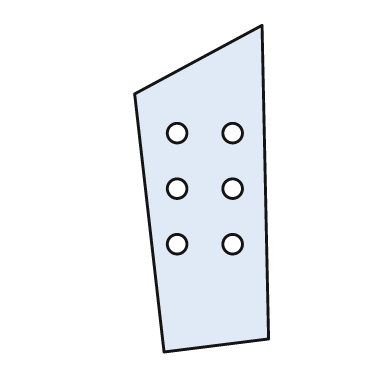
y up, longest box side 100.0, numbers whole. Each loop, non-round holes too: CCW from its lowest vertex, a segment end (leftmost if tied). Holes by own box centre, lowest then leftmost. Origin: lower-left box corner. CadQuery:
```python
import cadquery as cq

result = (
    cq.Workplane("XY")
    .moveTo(9.0, 0.0)
    .lineTo(41.0, 4.0)
    .lineTo(39.0, 100.0)
    .lineTo(0.0, 79.0)
    .close()
    .moveTo(13.0, 33.0)
    .circle(3.0)
    .moveTo(30.0, 33.0)
    .circle(3.0)
    .moveTo(13.0, 50.0)
    .circle(3.0)
    .moveTo(30.0, 50.0)
    .circle(3.0)
    .moveTo(13.0, 67.0)
    .circle(3.0)
    .moveTo(30.0, 67.0)
    .circle(3.0)
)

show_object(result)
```